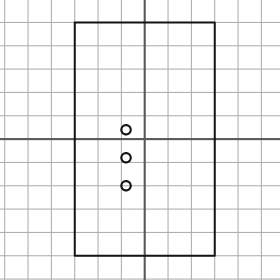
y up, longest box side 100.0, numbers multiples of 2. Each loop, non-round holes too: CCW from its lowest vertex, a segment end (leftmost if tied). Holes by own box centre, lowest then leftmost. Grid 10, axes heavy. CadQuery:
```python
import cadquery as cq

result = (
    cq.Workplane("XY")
    .moveTo(-30.0, -50.0)
    .lineTo(30.0, -50.0)
    .lineTo(30.0, 50.0)
    .lineTo(-30.0, 50.0)
    .close()
    .moveTo(-8.0, -20.0)
    .circle(2.0)
    .moveTo(-8.0, -8.0)
    .circle(2.0)
    .moveTo(-8.0, 4.0)
    .circle(2.0)
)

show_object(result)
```